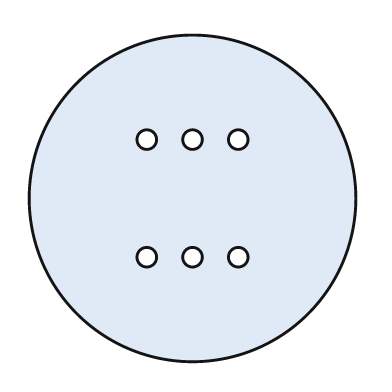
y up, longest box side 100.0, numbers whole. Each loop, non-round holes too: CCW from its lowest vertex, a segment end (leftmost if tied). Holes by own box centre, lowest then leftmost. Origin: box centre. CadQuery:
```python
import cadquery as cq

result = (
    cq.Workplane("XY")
    .moveTo(0.0, 0.0)
    .circle(50.0)
    .moveTo(-14.0, -18.0)
    .circle(3.0)
    .moveTo(0.0, -18.0)
    .circle(3.0)
    .moveTo(14.0, -18.0)
    .circle(3.0)
    .moveTo(-14.0, 18.0)
    .circle(3.0)
    .moveTo(0.0, 18.0)
    .circle(3.0)
    .moveTo(14.0, 18.0)
    .circle(3.0)
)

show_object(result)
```